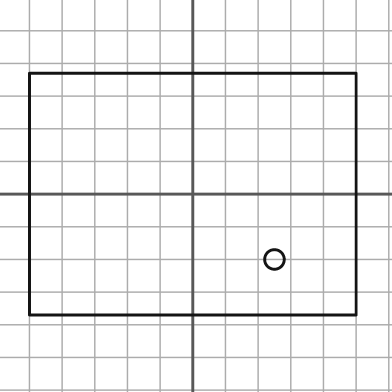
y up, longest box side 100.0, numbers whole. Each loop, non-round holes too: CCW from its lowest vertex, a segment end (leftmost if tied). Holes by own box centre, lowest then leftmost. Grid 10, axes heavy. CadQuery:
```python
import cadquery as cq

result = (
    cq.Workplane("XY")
    .moveTo(-50.0, -37.0)
    .lineTo(50.0, -37.0)
    .lineTo(50.0, 37.0)
    .lineTo(-50.0, 37.0)
    .close()
    .moveTo(25.0, -20.0)
    .circle(3.0)
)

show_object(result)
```